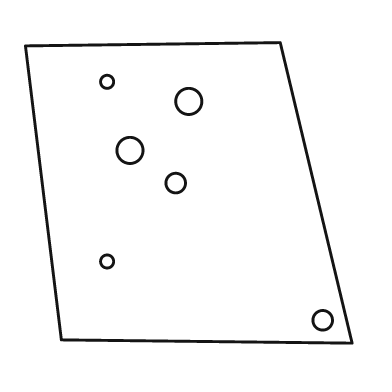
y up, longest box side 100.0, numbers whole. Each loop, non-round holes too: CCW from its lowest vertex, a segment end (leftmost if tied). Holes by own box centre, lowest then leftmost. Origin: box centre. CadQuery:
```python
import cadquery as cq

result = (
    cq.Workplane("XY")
    .moveTo(50.0, -46.0)
    .lineTo(28.0, 46.0)
    .lineTo(-50.0, 45.0)
    .lineTo(-39.0, -45.0)
    .close()
    .moveTo(41.0, -39.0)
    .circle(3.0)
    .moveTo(-25.0, -21.0)
    .circle(2.0)
    .moveTo(-4.0, 3.0)
    .circle(3.0)
    .moveTo(-18.0, 13.0)
    .circle(4.0)
    .moveTo(0.0, 28.0)
    .circle(4.0)
    .moveTo(-25.0, 34.0)
    .circle(2.0)
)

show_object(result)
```